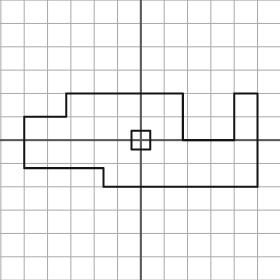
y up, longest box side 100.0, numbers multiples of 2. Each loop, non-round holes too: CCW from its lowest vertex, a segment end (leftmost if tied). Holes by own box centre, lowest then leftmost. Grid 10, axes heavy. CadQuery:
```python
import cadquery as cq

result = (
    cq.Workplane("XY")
    .moveTo(-16.0, -20.0)
    .lineTo(50.0, -20.0)
    .lineTo(50.0, 20.0)
    .lineTo(40.0, 20.0)
    .lineTo(40.0, 0.0)
    .lineTo(18.0, 0.0)
    .lineTo(18.0, 20.0)
    .lineTo(-32.0, 20.0)
    .lineTo(-32.0, 10.0)
    .lineTo(-50.0, 10.0)
    .lineTo(-50.0, -12.0)
    .lineTo(-16.0, -12.0)
    .close()
    .moveTo(-4.0, -4.0)
    .lineTo(4.0, -4.0)
    .lineTo(4.0, 4.0)
    .lineTo(-4.0, 4.0)
    .close()
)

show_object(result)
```